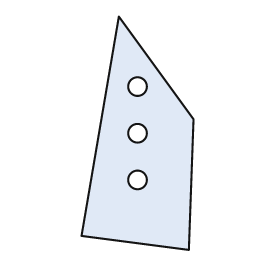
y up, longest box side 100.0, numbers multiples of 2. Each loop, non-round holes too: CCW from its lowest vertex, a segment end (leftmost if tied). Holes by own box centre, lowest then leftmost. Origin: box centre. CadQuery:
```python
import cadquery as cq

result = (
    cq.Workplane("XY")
    .moveTo(22.0, -50.0)
    .lineTo(24.0, 6.0)
    .lineTo(-8.0, 50.0)
    .lineTo(-24.0, -44.0)
    .close()
    .moveTo(0.0, -20.0)
    .circle(4.0)
    .moveTo(0.0, 0.0)
    .circle(4.0)
    .moveTo(0.0, 20.0)
    .circle(4.0)
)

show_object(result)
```